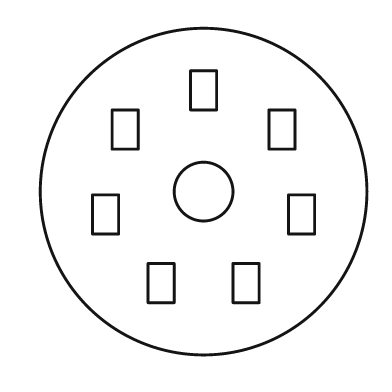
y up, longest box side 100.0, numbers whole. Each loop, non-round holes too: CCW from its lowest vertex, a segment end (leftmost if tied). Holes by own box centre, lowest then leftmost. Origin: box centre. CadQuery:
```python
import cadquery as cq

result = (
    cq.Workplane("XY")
    .moveTo(0.0, 0.0)
    .circle(50.0)
    .moveTo(-17.0, -34.0)
    .lineTo(-9.0, -34.0)
    .lineTo(-9.0, -22.0)
    .lineTo(-17.0, -22.0)
    .close()
    .moveTo(9.0, -34.0)
    .lineTo(17.0, -34.0)
    .lineTo(17.0, -22.0)
    .lineTo(9.0, -22.0)
    .close()
    .moveTo(-34.0, -13.0)
    .lineTo(-26.0, -13.0)
    .lineTo(-26.0, -1.0)
    .lineTo(-34.0, -1.0)
    .close()
    .moveTo(26.0, -13.0)
    .lineTo(34.0, -13.0)
    .lineTo(34.0, -1.0)
    .lineTo(26.0, -1.0)
    .close()
    .moveTo(0.0, 0.0)
    .circle(9.0)
    .moveTo(-28.0, 13.0)
    .lineTo(-20.0, 13.0)
    .lineTo(-20.0, 25.0)
    .lineTo(-28.0, 25.0)
    .close()
    .moveTo(20.0, 13.0)
    .lineTo(28.0, 13.0)
    .lineTo(28.0, 25.0)
    .lineTo(20.0, 25.0)
    .close()
    .moveTo(-4.0, 25.0)
    .lineTo(4.0, 25.0)
    .lineTo(4.0, 37.0)
    .lineTo(-4.0, 37.0)
    .close()
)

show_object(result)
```